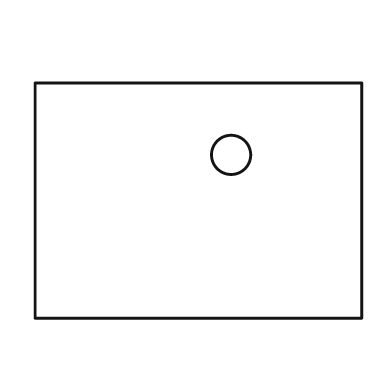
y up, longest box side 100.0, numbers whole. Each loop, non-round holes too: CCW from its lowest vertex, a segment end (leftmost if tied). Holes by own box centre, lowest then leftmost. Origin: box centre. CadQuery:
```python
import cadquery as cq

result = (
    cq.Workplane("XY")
    .moveTo(-50.0, -36.0)
    .lineTo(50.0, -36.0)
    .lineTo(50.0, 36.0)
    .lineTo(-50.0, 36.0)
    .close()
    .moveTo(10.0, 14.0)
    .circle(6.0)
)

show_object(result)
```